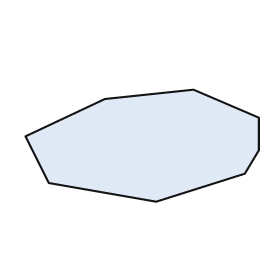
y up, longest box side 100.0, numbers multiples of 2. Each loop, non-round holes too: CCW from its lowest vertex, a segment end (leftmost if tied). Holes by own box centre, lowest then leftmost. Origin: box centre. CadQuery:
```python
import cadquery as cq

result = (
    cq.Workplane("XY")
    .moveTo(6.0, -24.0)
    .lineTo(44.0, -12.0)
    .lineTo(50.0, -2.0)
    .lineTo(50.0, 12.0)
    .lineTo(22.0, 24.0)
    .lineTo(-16.0, 20.0)
    .lineTo(-50.0, 4.0)
    .lineTo(-40.0, -16.0)
    .close()
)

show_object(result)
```